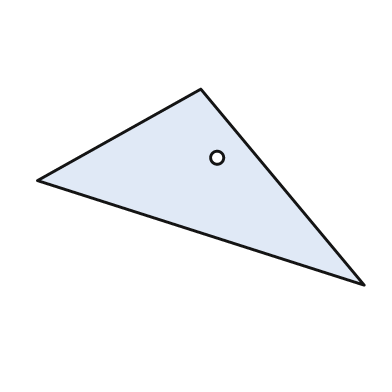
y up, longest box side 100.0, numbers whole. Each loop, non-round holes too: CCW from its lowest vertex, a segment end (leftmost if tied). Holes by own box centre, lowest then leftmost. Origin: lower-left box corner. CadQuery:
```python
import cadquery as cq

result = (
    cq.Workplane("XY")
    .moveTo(100.0, 0.0)
    .lineTo(50.0, 60.0)
    .lineTo(0.0, 32.0)
    .close()
    .moveTo(55.0, 39.0)
    .circle(2.0)
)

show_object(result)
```